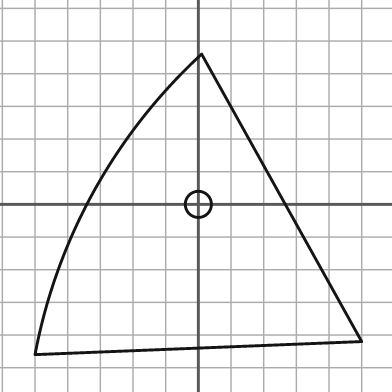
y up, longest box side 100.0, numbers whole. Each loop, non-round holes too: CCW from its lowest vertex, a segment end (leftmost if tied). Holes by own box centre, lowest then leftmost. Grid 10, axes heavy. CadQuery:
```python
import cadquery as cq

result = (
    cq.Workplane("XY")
    .moveTo(-50.0, -46.0)
    .lineTo(50.0, -42.0)
    .lineTo(1.0, 46.0)
    .threePointArc((-32.0, 4.0), (-50.0, -46.0))
    .close()
    .moveTo(0.0, 0.0)
    .circle(4.0)
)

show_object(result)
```